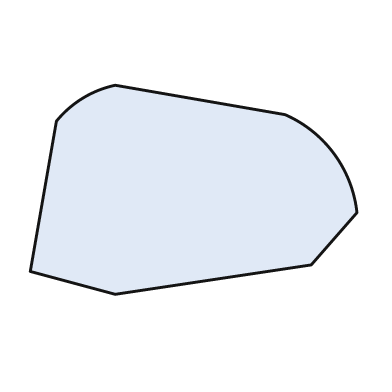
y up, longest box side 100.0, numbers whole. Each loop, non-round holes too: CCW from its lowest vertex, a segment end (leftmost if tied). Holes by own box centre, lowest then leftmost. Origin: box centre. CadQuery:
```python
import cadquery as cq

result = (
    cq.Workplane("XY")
    .moveTo(-24.0, -32.0)
    .lineTo(36.0, -23.0)
    .lineTo(50.0, -7.0)
    .threePointArc((43.0, 11.0), (28.0, 23.0))
    .lineTo(-24.0, 32.0)
    .threePointArc((-34.0, 28.0), (-42.0, 21.0))
    .lineTo(-50.0, -25.0)
    .close()
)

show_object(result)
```